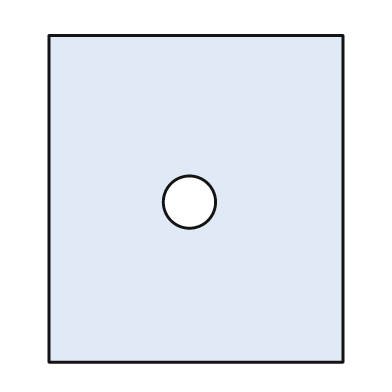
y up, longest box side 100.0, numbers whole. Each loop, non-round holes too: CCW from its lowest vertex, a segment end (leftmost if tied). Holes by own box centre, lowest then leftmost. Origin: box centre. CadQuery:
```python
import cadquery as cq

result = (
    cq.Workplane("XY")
    .moveTo(-45.0, -50.0)
    .lineTo(45.0, -50.0)
    .lineTo(45.0, 50.0)
    .lineTo(-45.0, 50.0)
    .close()
    .moveTo(-2.0, -1.0)
    .circle(8.0)
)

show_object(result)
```